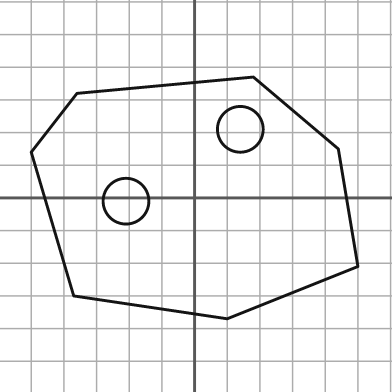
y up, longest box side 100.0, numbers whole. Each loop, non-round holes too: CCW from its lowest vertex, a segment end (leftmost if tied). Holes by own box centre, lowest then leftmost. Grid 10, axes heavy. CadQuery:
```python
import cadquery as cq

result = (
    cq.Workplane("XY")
    .moveTo(10.0, -37.0)
    .lineTo(50.0, -21.0)
    .lineTo(44.0, 15.0)
    .lineTo(18.0, 37.0)
    .lineTo(-36.0, 32.0)
    .lineTo(-50.0, 14.0)
    .lineTo(-37.0, -30.0)
    .close()
    .moveTo(-21.0, -1.0)
    .circle(7.0)
    .moveTo(14.0, 21.0)
    .circle(7.0)
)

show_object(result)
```